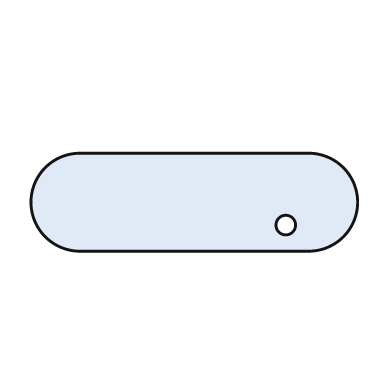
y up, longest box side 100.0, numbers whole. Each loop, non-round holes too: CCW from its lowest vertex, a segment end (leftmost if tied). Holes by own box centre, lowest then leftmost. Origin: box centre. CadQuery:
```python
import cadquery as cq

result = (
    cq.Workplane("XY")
    .moveTo(-35.0, -15.0)
    .lineTo(35.0, -15.0)
    .threePointArc((50.0, 0.0), (35.0, 15.0))
    .lineTo(-35.0, 15.0)
    .threePointArc((-50.0, 0.0), (-35.0, -15.0))
    .close()
    .moveTo(28.0, -7.0)
    .circle(3.0)
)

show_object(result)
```